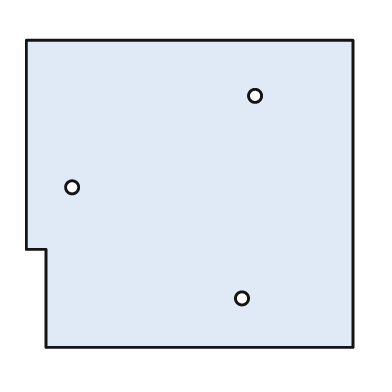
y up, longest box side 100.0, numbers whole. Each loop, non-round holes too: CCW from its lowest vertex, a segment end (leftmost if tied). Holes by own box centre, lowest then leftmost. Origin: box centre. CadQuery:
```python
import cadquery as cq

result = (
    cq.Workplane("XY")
    .moveTo(-44.0, -47.0)
    .lineTo(50.0, -47.0)
    .lineTo(50.0, 47.0)
    .lineTo(-50.0, 47.0)
    .lineTo(-50.0, -17.0)
    .lineTo(-44.0, -17.0)
    .close()
    .moveTo(16.0, -32.0)
    .circle(2.0)
    .moveTo(-36.0, 2.0)
    .circle(2.0)
    .moveTo(20.0, 30.0)
    .circle(2.0)
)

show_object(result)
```